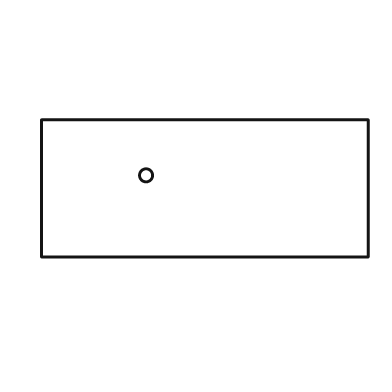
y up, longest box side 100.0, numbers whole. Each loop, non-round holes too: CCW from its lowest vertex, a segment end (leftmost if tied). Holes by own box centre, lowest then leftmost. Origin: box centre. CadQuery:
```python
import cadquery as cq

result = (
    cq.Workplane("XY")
    .moveTo(-50.0, -21.0)
    .lineTo(50.0, -21.0)
    .lineTo(50.0, 21.0)
    .lineTo(-50.0, 21.0)
    .close()
    .moveTo(-18.0, 4.0)
    .circle(2.0)
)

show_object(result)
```